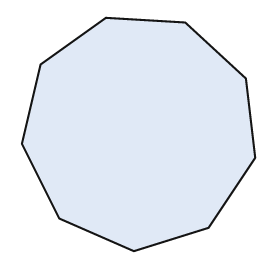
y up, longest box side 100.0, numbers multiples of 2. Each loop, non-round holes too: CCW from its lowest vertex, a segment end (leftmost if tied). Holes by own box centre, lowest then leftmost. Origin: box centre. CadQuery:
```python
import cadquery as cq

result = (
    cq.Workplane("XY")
    .moveTo(-2.0, -50.0)
    .lineTo(30.0, -40.0)
    .lineTo(50.0, -10.0)
    .lineTo(46.0, 24.0)
    .lineTo(20.0, 48.0)
    .lineTo(-14.0, 50.0)
    .lineTo(-42.0, 30.0)
    .lineTo(-50.0, -4.0)
    .lineTo(-34.0, -36.0)
    .close()
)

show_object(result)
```